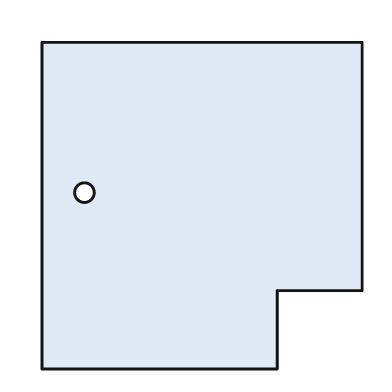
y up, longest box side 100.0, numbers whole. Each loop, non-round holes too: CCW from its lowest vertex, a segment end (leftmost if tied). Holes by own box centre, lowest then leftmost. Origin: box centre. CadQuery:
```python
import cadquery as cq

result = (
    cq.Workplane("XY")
    .moveTo(-49.0, -50.0)
    .lineTo(23.0, -50.0)
    .lineTo(23.0, -26.0)
    .lineTo(49.0, -26.0)
    .lineTo(49.0, 50.0)
    .lineTo(-49.0, 50.0)
    .close()
    .moveTo(-36.0, 4.0)
    .circle(3.0)
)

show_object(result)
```